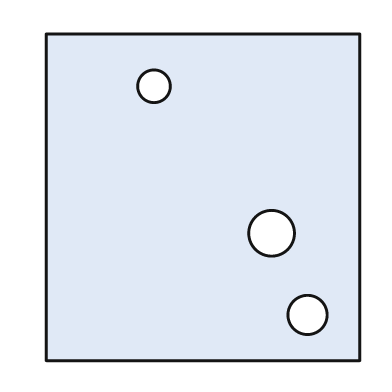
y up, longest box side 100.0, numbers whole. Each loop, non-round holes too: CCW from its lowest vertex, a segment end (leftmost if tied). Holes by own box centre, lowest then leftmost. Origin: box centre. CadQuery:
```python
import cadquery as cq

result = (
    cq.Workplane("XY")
    .moveTo(-48.0, -50.0)
    .lineTo(48.0, -50.0)
    .lineTo(48.0, 50.0)
    .lineTo(-48.0, 50.0)
    .close()
    .moveTo(32.0, -36.0)
    .circle(6.0)
    .moveTo(21.0, -11.0)
    .circle(7.0)
    .moveTo(-15.0, 34.0)
    .circle(5.0)
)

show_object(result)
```